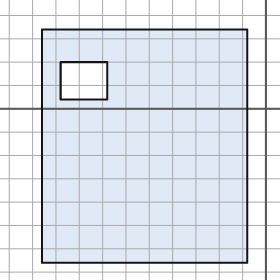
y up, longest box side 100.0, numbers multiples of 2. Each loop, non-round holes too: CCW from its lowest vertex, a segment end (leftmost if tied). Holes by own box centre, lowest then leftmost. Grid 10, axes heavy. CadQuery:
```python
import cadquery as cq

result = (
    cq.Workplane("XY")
    .moveTo(-96.0, -66.0)
    .lineTo(-8.0, -66.0)
    .lineTo(-8.0, 34.0)
    .lineTo(-96.0, 34.0)
    .close()
    .moveTo(-88.0, 4.0)
    .lineTo(-68.0, 4.0)
    .lineTo(-68.0, 20.0)
    .lineTo(-88.0, 20.0)
    .close()
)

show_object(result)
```